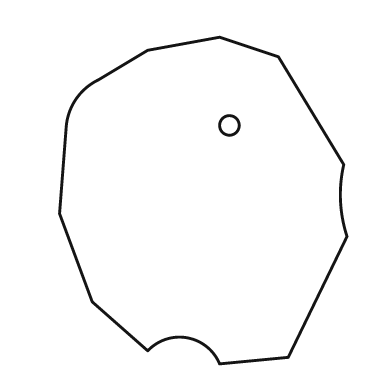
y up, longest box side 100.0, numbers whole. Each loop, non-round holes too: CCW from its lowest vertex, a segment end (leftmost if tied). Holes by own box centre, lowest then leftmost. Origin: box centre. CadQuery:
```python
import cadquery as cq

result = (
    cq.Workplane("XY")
    .moveTo(5.0, -50.0)
    .lineTo(26.0, -48.0)
    .lineTo(44.0, -11.0)
    .threePointArc((42.0, 0.0), (43.0, 11.0))
    .lineTo(23.0, 44.0)
    .lineTo(5.0, 50.0)
    .lineTo(-17.0, 46.0)
    .lineTo(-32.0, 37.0)
    .threePointArc((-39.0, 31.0), (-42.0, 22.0))
    .lineTo(-44.0, -4.0)
    .lineTo(-34.0, -31.0)
    .lineTo(-17.0, -46.0)
    .threePointArc((-5.0, -42.0), (5.0, -50.0))
    .close()
    .moveTo(8.0, 23.0)
    .circle(3.0)
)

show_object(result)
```